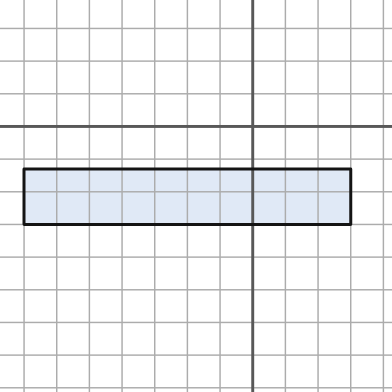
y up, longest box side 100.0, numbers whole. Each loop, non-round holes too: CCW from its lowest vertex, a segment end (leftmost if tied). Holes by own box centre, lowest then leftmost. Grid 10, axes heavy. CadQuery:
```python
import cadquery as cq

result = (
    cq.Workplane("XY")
    .moveTo(-70.0, -30.0)
    .lineTo(30.0, -30.0)
    .lineTo(30.0, -13.0)
    .lineTo(-70.0, -13.0)
    .close()
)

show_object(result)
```